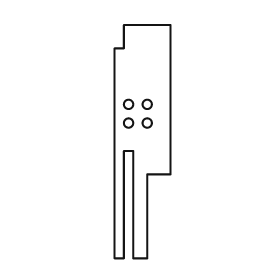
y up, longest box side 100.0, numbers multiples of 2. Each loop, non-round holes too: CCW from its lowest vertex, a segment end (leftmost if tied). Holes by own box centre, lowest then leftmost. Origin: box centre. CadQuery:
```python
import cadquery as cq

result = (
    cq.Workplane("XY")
    .moveTo(-12.0, -50.0)
    .lineTo(-8.0, -50.0)
    .lineTo(-8.0, -4.0)
    .lineTo(-4.0, -4.0)
    .lineTo(-4.0, -50.0)
    .lineTo(2.0, -50.0)
    .lineTo(2.0, -14.0)
    .lineTo(12.0, -14.0)
    .lineTo(12.0, 50.0)
    .lineTo(-8.0, 50.0)
    .lineTo(-8.0, 40.0)
    .lineTo(-12.0, 40.0)
    .close()
    .moveTo(-6.0, 8.0)
    .circle(2.0)
    .moveTo(2.0, 8.0)
    .circle(2.0)
    .moveTo(-6.0, 16.0)
    .circle(2.0)
    .moveTo(2.0, 16.0)
    .circle(2.0)
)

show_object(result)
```